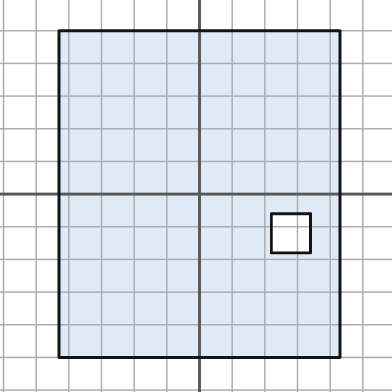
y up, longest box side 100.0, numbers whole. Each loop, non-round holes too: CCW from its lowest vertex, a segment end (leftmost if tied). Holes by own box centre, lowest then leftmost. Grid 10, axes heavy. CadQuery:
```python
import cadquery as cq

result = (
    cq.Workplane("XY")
    .moveTo(-43.0, -50.0)
    .lineTo(43.0, -50.0)
    .lineTo(43.0, 50.0)
    .lineTo(-43.0, 50.0)
    .close()
    .moveTo(22.0, -18.0)
    .lineTo(34.0, -18.0)
    .lineTo(34.0, -6.0)
    .lineTo(22.0, -6.0)
    .close()
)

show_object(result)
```